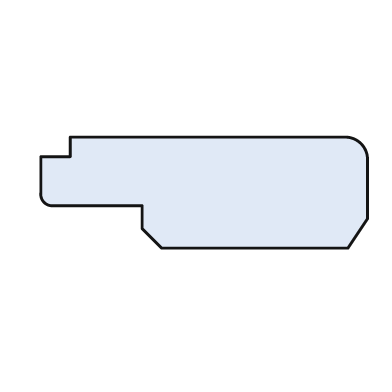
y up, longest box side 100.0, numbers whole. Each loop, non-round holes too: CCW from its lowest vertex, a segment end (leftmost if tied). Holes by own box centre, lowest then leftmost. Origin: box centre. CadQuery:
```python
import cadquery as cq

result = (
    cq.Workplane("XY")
    .moveTo(-13.0, -17.0)
    .lineTo(44.0, -17.0)
    .lineTo(50.0, -8.0)
    .lineTo(50.0, 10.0)
    .threePointArc((48.0, 15.0), (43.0, 17.0))
    .lineTo(-41.0, 17.0)
    .lineTo(-41.0, 11.0)
    .lineTo(-50.0, 11.0)
    .lineTo(-50.0, 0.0)
    .threePointArc((-49.0, -3.0), (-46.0, -4.0))
    .lineTo(-19.0, -4.0)
    .lineTo(-19.0, -11.0)
    .close()
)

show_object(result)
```